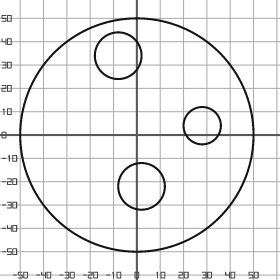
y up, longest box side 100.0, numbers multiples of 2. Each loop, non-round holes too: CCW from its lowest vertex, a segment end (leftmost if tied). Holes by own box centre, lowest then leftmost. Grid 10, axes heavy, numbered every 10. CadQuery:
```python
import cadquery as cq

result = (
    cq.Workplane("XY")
    .moveTo(0.0, 0.0)
    .circle(50.0)
    .moveTo(2.0, -22.0)
    .circle(10.0)
    .moveTo(28.0, 4.0)
    .circle(8.0)
    .moveTo(-8.0, 34.0)
    .circle(10.0)
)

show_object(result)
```